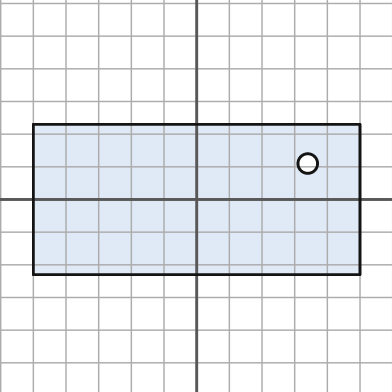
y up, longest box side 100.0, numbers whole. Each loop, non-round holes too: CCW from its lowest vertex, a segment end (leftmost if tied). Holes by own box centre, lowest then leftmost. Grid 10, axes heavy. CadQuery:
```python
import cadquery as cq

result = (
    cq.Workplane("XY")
    .moveTo(-50.0, -23.0)
    .lineTo(50.0, -23.0)
    .lineTo(50.0, 23.0)
    .lineTo(-50.0, 23.0)
    .close()
    .moveTo(34.0, 11.0)
    .circle(3.0)
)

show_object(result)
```